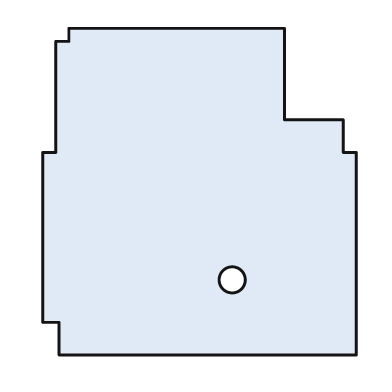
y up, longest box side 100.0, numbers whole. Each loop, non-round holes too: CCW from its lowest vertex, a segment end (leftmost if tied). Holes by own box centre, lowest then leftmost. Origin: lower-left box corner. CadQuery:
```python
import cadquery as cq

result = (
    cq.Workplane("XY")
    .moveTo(5.0, 0.0)
    .lineTo(96.0, 0.0)
    .lineTo(96.0, 62.0)
    .lineTo(92.0, 62.0)
    .lineTo(92.0, 72.0)
    .lineTo(74.0, 72.0)
    .lineTo(74.0, 100.0)
    .lineTo(8.0, 100.0)
    .lineTo(8.0, 96.0)
    .lineTo(4.0, 96.0)
    .lineTo(4.0, 62.0)
    .lineTo(0.0, 62.0)
    .lineTo(0.0, 10.0)
    .lineTo(5.0, 10.0)
    .close()
    .moveTo(58.0, 23.0)
    .circle(4.0)
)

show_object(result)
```